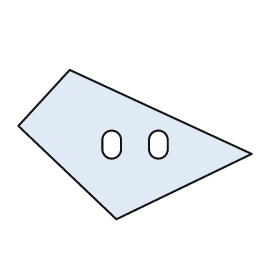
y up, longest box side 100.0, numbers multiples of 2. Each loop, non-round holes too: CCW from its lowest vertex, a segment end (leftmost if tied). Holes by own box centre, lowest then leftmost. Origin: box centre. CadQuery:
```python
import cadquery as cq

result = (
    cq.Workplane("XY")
    .moveTo(-8.0, -32.0)
    .lineTo(50.0, -4.0)
    .lineTo(-28.0, 32.0)
    .lineTo(-50.0, 8.0)
    .close()
    .moveTo(-14.0, -2.0)
    .threePointArc((-10.0, -6.0), (-6.0, -2.0))
    .lineTo(-6.0, 2.0)
    .threePointArc((-10.0, 6.0), (-14.0, 2.0))
    .close()
    .moveTo(6.0, -2.0)
    .threePointArc((10.0, -6.0), (14.0, -2.0))
    .lineTo(14.0, 2.0)
    .threePointArc((10.0, 6.0), (6.0, 2.0))
    .close()
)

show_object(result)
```